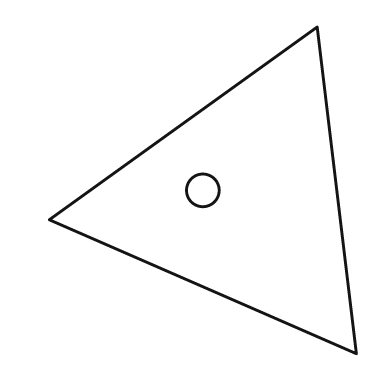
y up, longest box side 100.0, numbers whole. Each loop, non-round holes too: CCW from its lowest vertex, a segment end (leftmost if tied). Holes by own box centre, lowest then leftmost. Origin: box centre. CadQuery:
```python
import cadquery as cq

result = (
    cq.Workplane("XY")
    .moveTo(47.0, -50.0)
    .lineTo(35.0, 50.0)
    .lineTo(-47.0, -9.0)
    .close()
    .moveTo(0.0, 0.0)
    .circle(5.0)
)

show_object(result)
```